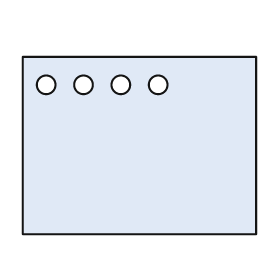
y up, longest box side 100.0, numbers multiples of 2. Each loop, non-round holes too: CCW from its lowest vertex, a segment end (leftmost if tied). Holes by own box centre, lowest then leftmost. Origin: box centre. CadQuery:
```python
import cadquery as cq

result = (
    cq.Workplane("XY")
    .moveTo(-50.0, -38.0)
    .lineTo(50.0, -38.0)
    .lineTo(50.0, 38.0)
    .lineTo(-50.0, 38.0)
    .close()
    .moveTo(-40.0, 26.0)
    .circle(4.0)
    .moveTo(-24.0, 26.0)
    .circle(4.0)
    .moveTo(-8.0, 26.0)
    .circle(4.0)
    .moveTo(8.0, 26.0)
    .circle(4.0)
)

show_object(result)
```